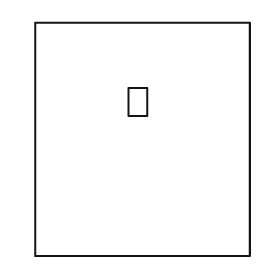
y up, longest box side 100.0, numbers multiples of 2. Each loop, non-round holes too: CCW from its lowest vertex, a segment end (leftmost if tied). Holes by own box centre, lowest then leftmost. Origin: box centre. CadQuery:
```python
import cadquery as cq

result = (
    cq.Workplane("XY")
    .moveTo(-46.0, -50.0)
    .lineTo(46.0, -50.0)
    .lineTo(46.0, 50.0)
    .lineTo(-46.0, 50.0)
    .close()
    .moveTo(-6.0, 10.0)
    .lineTo(2.0, 10.0)
    .lineTo(2.0, 22.0)
    .lineTo(-6.0, 22.0)
    .close()
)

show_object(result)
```